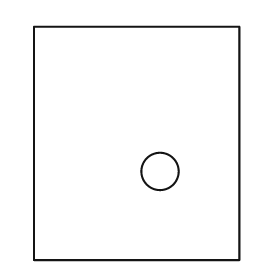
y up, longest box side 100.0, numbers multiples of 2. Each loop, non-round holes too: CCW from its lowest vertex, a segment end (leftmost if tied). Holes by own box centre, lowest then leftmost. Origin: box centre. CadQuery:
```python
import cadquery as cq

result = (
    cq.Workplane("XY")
    .moveTo(-44.0, -50.0)
    .lineTo(44.0, -50.0)
    .lineTo(44.0, 50.0)
    .lineTo(-44.0, 50.0)
    .close()
    .moveTo(10.0, -12.0)
    .circle(8.0)
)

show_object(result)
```